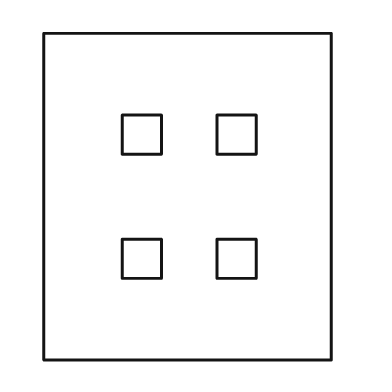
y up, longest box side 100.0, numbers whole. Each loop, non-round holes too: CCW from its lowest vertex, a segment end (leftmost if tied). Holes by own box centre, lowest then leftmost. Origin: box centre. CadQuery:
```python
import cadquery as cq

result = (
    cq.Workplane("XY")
    .moveTo(-44.0, -50.0)
    .lineTo(44.0, -50.0)
    .lineTo(44.0, 50.0)
    .lineTo(-44.0, 50.0)
    .close()
    .moveTo(-20.0, -25.0)
    .lineTo(-8.0, -25.0)
    .lineTo(-8.0, -13.0)
    .lineTo(-20.0, -13.0)
    .close()
    .moveTo(9.0, -25.0)
    .lineTo(21.0, -25.0)
    .lineTo(21.0, -13.0)
    .lineTo(9.0, -13.0)
    .close()
    .moveTo(-20.0, 13.0)
    .lineTo(-8.0, 13.0)
    .lineTo(-8.0, 25.0)
    .lineTo(-20.0, 25.0)
    .close()
    .moveTo(9.0, 13.0)
    .lineTo(21.0, 13.0)
    .lineTo(21.0, 25.0)
    .lineTo(9.0, 25.0)
    .close()
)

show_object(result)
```